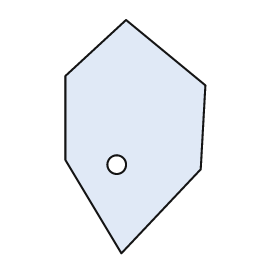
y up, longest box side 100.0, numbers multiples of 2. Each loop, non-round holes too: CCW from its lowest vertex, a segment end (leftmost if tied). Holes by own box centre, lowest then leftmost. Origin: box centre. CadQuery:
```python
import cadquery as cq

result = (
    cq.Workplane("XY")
    .moveTo(-6.0, -50.0)
    .lineTo(28.0, -14.0)
    .lineTo(30.0, 22.0)
    .lineTo(-4.0, 50.0)
    .lineTo(-30.0, 26.0)
    .lineTo(-30.0, -10.0)
    .close()
    .moveTo(-8.0, -12.0)
    .circle(4.0)
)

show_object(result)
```